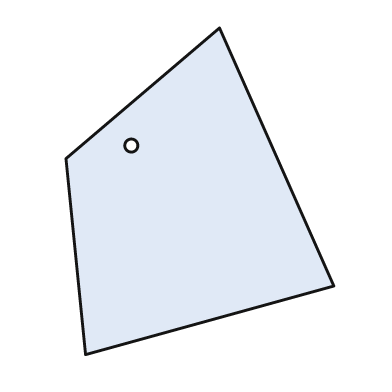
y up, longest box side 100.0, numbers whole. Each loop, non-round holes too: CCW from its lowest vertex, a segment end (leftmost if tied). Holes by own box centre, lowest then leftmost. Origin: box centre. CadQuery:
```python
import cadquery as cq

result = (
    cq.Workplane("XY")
    .moveTo(-35.0, -50.0)
    .lineTo(41.0, -29.0)
    .lineTo(6.0, 50.0)
    .lineTo(-41.0, 10.0)
    .close()
    .moveTo(-21.0, 14.0)
    .circle(2.0)
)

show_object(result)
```